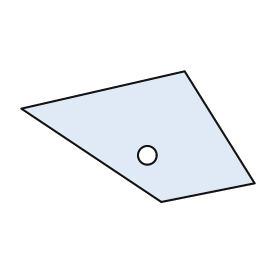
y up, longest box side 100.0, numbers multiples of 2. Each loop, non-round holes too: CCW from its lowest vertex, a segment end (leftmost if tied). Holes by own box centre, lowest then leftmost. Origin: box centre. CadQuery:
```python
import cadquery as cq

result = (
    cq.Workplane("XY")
    .moveTo(10.0, -28.0)
    .lineTo(50.0, -20.0)
    .lineTo(20.0, 28.0)
    .lineTo(-50.0, 12.0)
    .close()
    .moveTo(4.0, -8.0)
    .circle(4.0)
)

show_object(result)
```